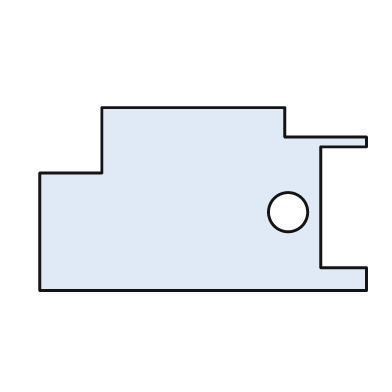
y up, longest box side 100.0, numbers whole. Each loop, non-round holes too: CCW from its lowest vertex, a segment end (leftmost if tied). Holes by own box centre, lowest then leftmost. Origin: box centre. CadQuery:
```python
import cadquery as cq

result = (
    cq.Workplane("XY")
    .moveTo(-50.0, -28.0)
    .lineTo(50.0, -28.0)
    .lineTo(50.0, -21.0)
    .lineTo(36.0, -21.0)
    .lineTo(36.0, 16.0)
    .lineTo(50.0, 16.0)
    .lineTo(50.0, 19.0)
    .lineTo(25.0, 19.0)
    .lineTo(25.0, 28.0)
    .lineTo(-31.0, 28.0)
    .lineTo(-31.0, 8.0)
    .lineTo(-50.0, 8.0)
    .close()
    .moveTo(26.0, -4.0)
    .circle(6.0)
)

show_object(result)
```